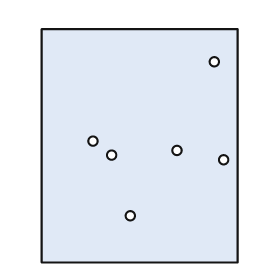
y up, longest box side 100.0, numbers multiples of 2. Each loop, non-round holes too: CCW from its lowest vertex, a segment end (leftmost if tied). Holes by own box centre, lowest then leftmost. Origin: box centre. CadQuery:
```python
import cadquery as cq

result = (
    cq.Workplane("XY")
    .moveTo(-42.0, -50.0)
    .lineTo(42.0, -50.0)
    .lineTo(42.0, 50.0)
    .lineTo(-42.0, 50.0)
    .close()
    .moveTo(-4.0, -30.0)
    .circle(2.0)
    .moveTo(36.0, -6.0)
    .circle(2.0)
    .moveTo(-12.0, -4.0)
    .circle(2.0)
    .moveTo(16.0, -2.0)
    .circle(2.0)
    .moveTo(-20.0, 2.0)
    .circle(2.0)
    .moveTo(32.0, 36.0)
    .circle(2.0)
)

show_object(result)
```